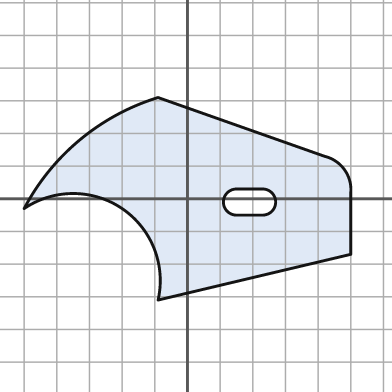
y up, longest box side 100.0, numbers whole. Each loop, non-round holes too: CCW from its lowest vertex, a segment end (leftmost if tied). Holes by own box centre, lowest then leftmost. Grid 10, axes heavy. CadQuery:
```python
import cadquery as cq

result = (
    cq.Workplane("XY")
    .moveTo(-9.0, -31.0)
    .lineTo(50.0, -17.0)
    .lineTo(50.0, 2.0)
    .threePointArc((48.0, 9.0), (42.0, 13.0))
    .lineTo(-9.0, 31.0)
    .threePointArc((-33.0, 18.0), (-50.0, -3.0))
    .threePointArc((-20.0, -3.0), (-9.0, -31.0))
    .close()
    .moveTo(15.0, -5.0)
    .lineTo(23.0, -5.0)
    .threePointArc((27.0, -1.0), (23.0, 3.0))
    .lineTo(15.0, 3.0)
    .threePointArc((11.0, -1.0), (15.0, -5.0))
    .close()
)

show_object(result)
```